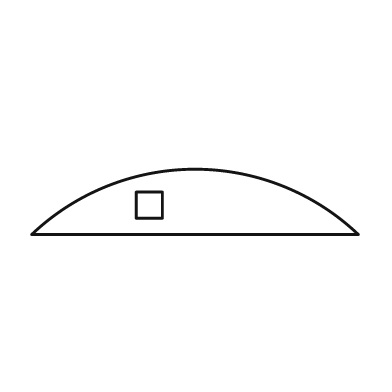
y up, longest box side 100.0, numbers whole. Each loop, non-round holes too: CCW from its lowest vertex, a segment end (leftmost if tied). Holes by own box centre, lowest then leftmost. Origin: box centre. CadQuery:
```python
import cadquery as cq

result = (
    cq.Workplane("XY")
    .moveTo(-50.0, -10.0)
    .lineTo(50.0, -10.0)
    .threePointArc((0.0, 10.0), (-50.0, -10.0))
    .close()
    .moveTo(-18.0, -5.0)
    .lineTo(-10.0, -5.0)
    .lineTo(-10.0, 3.0)
    .lineTo(-18.0, 3.0)
    .close()
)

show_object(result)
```